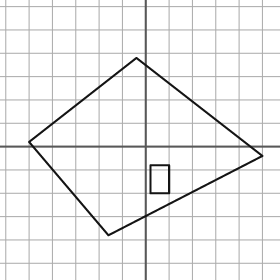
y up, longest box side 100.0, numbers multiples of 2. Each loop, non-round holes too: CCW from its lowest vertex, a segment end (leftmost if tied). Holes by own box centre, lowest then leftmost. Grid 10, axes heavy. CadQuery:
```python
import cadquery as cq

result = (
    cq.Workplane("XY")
    .moveTo(-16.0, -38.0)
    .lineTo(50.0, -4.0)
    .lineTo(-4.0, 38.0)
    .lineTo(-50.0, 2.0)
    .close()
    .moveTo(2.0, -20.0)
    .lineTo(10.0, -20.0)
    .lineTo(10.0, -8.0)
    .lineTo(2.0, -8.0)
    .close()
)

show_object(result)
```